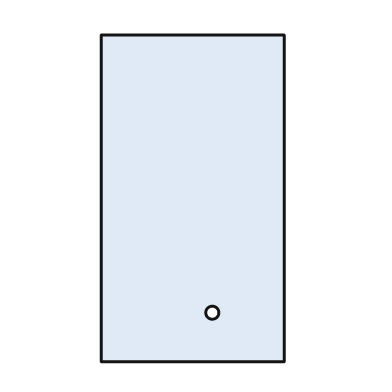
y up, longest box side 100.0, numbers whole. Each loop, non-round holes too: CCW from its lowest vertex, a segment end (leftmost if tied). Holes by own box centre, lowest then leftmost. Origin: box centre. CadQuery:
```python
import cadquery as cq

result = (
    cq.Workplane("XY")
    .moveTo(-28.0, -50.0)
    .lineTo(28.0, -50.0)
    .lineTo(28.0, 50.0)
    .lineTo(-28.0, 50.0)
    .close()
    .moveTo(6.0, -35.0)
    .circle(2.0)
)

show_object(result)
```